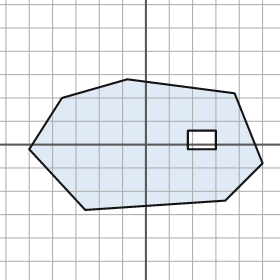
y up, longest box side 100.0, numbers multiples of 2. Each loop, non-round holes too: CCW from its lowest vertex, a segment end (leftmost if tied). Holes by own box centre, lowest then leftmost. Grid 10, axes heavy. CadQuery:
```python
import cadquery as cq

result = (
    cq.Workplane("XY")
    .moveTo(-26.0, -28.0)
    .lineTo(34.0, -24.0)
    .lineTo(50.0, -8.0)
    .lineTo(38.0, 22.0)
    .lineTo(-8.0, 28.0)
    .lineTo(-36.0, 20.0)
    .lineTo(-50.0, -2.0)
    .close()
    .moveTo(18.0, -2.0)
    .lineTo(30.0, -2.0)
    .lineTo(30.0, 6.0)
    .lineTo(18.0, 6.0)
    .close()
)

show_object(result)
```